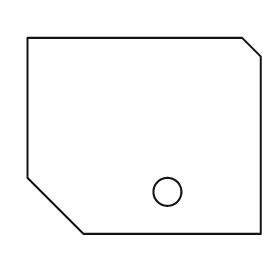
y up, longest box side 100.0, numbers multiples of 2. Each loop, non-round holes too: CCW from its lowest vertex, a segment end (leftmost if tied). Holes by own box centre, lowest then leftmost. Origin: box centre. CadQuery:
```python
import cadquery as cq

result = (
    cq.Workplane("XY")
    .moveTo(-26.0, -42.0)
    .lineTo(50.0, -42.0)
    .lineTo(50.0, 34.0)
    .lineTo(42.0, 42.0)
    .lineTo(-50.0, 42.0)
    .lineTo(-50.0, -18.0)
    .close()
    .moveTo(10.0, -24.0)
    .circle(6.0)
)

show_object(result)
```